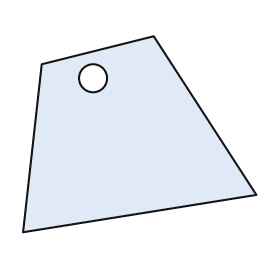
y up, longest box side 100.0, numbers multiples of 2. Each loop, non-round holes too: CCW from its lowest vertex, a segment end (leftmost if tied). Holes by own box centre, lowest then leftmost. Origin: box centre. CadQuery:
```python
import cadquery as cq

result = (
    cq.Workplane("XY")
    .moveTo(-50.0, -42.0)
    .lineTo(50.0, -26.0)
    .lineTo(6.0, 42.0)
    .lineTo(-42.0, 30.0)
    .close()
    .moveTo(-20.0, 24.0)
    .circle(6.0)
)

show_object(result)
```